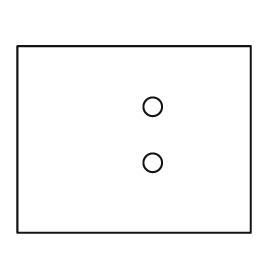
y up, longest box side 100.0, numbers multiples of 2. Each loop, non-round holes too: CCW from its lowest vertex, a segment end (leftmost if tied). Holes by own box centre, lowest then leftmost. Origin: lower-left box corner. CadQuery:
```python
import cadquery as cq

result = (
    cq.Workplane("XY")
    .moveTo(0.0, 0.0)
    .lineTo(100.0, 0.0)
    .lineTo(100.0, 80.0)
    .lineTo(0.0, 80.0)
    .close()
    .moveTo(58.0, 30.0)
    .circle(4.0)
    .moveTo(58.0, 54.0)
    .circle(4.0)
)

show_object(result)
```